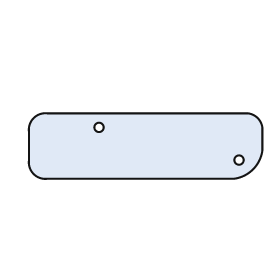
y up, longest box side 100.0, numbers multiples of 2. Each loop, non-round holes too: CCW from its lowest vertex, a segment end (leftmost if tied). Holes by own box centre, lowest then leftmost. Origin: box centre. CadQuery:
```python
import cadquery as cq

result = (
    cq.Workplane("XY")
    .moveTo(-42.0, -14.0)
    .lineTo(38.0, -14.0)
    .threePointArc((46.0, -10.0), (50.0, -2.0))
    .lineTo(50.0, 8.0)
    .threePointArc((48.0, 12.0), (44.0, 14.0))
    .lineTo(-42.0, 14.0)
    .threePointArc((-48.0, 12.0), (-50.0, 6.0))
    .lineTo(-50.0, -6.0)
    .threePointArc((-48.0, -12.0), (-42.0, -14.0))
    .close()
    .moveTo(40.0, -6.0)
    .circle(2.0)
    .moveTo(-20.0, 8.0)
    .circle(2.0)
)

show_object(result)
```